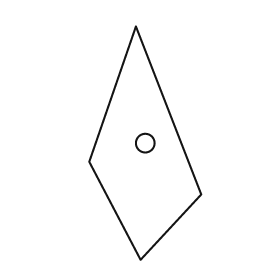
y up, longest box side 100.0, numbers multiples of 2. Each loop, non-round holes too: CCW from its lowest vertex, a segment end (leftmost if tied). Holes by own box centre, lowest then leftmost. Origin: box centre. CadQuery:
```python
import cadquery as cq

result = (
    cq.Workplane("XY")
    .moveTo(-2.0, -50.0)
    .lineTo(24.0, -22.0)
    .lineTo(-4.0, 50.0)
    .lineTo(-24.0, -8.0)
    .close()
    .moveTo(0.0, 0.0)
    .circle(4.0)
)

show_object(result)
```